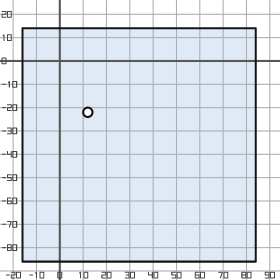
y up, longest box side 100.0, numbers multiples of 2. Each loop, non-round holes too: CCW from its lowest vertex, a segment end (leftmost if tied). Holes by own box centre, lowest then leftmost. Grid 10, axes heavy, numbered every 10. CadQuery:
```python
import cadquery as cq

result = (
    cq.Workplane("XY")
    .moveTo(-16.0, -86.0)
    .lineTo(84.0, -86.0)
    .lineTo(84.0, 14.0)
    .lineTo(-16.0, 14.0)
    .close()
    .moveTo(12.0, -22.0)
    .circle(2.0)
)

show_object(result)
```